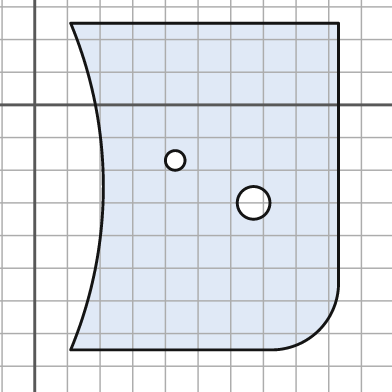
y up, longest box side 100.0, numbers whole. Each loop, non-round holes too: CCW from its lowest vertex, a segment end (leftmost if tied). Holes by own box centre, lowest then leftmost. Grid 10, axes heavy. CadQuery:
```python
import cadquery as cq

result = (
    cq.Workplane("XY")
    .moveTo(11.0, -75.0)
    .lineTo(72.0, -75.0)
    .threePointArc((87.0, -69.0), (93.0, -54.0))
    .lineTo(93.0, 25.0)
    .lineTo(11.0, 25.0)
    .threePointArc((21.0, -25.0), (11.0, -75.0))
    .close()
    .moveTo(67.0, -30.0)
    .circle(5.0)
    .moveTo(43.0, -17.0)
    .circle(3.0)
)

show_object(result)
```